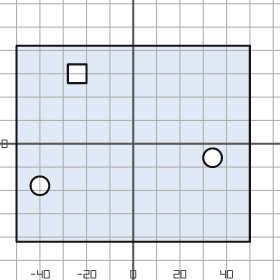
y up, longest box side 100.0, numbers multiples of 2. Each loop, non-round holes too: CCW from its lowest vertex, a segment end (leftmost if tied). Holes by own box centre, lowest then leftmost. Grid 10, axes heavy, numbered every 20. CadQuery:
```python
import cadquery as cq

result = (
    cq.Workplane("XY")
    .moveTo(-50.0, -42.0)
    .lineTo(50.0, -42.0)
    .lineTo(50.0, 42.0)
    .lineTo(-50.0, 42.0)
    .close()
    .moveTo(-40.0, -18.0)
    .circle(4.0)
    .moveTo(34.0, -6.0)
    .circle(4.0)
    .moveTo(-28.0, 26.0)
    .lineTo(-20.0, 26.0)
    .lineTo(-20.0, 34.0)
    .lineTo(-28.0, 34.0)
    .close()
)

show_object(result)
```